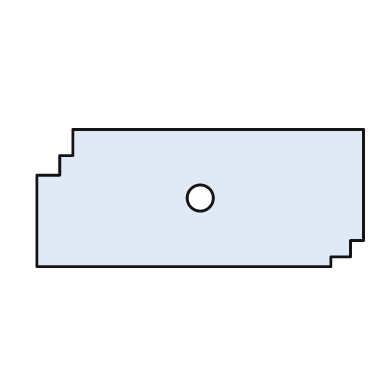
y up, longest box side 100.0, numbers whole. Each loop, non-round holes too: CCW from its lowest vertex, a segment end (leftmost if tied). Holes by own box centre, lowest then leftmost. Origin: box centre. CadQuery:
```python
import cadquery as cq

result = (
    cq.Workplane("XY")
    .moveTo(-50.0, -21.0)
    .lineTo(40.0, -21.0)
    .lineTo(40.0, -18.0)
    .lineTo(46.0, -18.0)
    .lineTo(46.0, -13.0)
    .lineTo(50.0, -13.0)
    .lineTo(50.0, 21.0)
    .lineTo(-39.0, 21.0)
    .lineTo(-39.0, 13.0)
    .lineTo(-43.0, 13.0)
    .lineTo(-43.0, 7.0)
    .lineTo(-50.0, 7.0)
    .close()
    .moveTo(0.0, 0.0)
    .circle(4.0)
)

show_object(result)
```